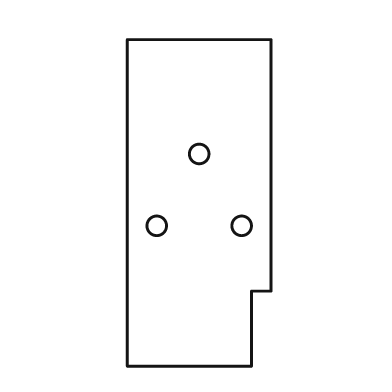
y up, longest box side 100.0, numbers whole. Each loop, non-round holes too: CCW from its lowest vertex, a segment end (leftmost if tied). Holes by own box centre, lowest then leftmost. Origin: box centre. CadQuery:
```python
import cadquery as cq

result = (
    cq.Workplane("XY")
    .moveTo(-22.0, -50.0)
    .lineTo(16.0, -50.0)
    .lineTo(16.0, -27.0)
    .lineTo(22.0, -27.0)
    .lineTo(22.0, 50.0)
    .lineTo(-22.0, 50.0)
    .close()
    .moveTo(-13.0, -7.0)
    .circle(3.0)
    .moveTo(13.0, -7.0)
    .circle(3.0)
    .moveTo(0.0, 15.0)
    .circle(3.0)
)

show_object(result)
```